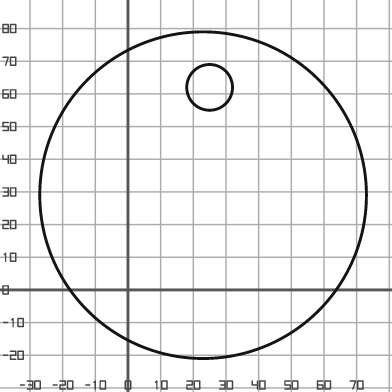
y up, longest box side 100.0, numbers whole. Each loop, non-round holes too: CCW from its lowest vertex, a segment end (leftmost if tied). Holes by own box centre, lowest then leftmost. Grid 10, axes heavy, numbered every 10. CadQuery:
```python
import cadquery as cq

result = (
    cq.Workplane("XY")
    .moveTo(23.0, 29.0)
    .circle(50.0)
    .moveTo(25.0, 62.0)
    .circle(7.0)
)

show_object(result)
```